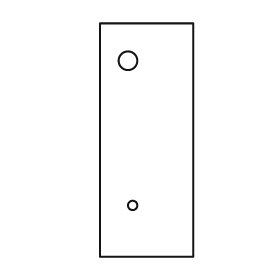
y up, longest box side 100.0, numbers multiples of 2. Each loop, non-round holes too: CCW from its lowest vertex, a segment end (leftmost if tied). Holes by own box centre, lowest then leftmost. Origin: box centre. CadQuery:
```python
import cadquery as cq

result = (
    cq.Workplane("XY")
    .moveTo(-20.0, -50.0)
    .lineTo(20.0, -50.0)
    .lineTo(20.0, 50.0)
    .lineTo(-20.0, 50.0)
    .close()
    .moveTo(-6.0, -28.0)
    .circle(2.0)
    .moveTo(-8.0, 34.0)
    .circle(4.0)
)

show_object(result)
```